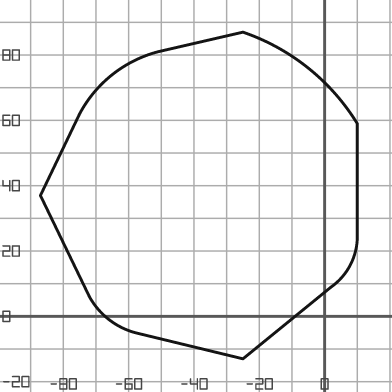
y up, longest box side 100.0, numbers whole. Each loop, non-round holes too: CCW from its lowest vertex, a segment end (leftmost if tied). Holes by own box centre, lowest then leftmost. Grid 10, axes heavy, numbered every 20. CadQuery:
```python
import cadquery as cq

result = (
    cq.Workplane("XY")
    .moveTo(-25.0, -13.0)
    .lineTo(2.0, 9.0)
    .threePointArc((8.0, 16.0), (10.0, 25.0))
    .lineTo(10.0, 59.0)
    .threePointArc((-5.0, 76.0), (-25.0, 87.0))
    .lineTo(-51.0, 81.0)
    .threePointArc((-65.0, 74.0), (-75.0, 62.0))
    .lineTo(-87.0, 37.0)
    .lineTo(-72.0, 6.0)
    .threePointArc((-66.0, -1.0), (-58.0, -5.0))
    .close()
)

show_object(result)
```